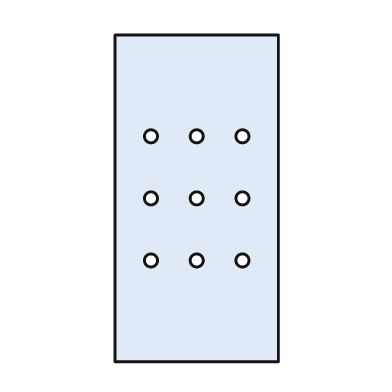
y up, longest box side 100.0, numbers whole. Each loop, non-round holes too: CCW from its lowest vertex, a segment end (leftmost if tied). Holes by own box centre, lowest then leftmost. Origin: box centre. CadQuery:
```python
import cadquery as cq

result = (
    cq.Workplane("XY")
    .moveTo(-25.0, -50.0)
    .lineTo(25.0, -50.0)
    .lineTo(25.0, 50.0)
    .lineTo(-25.0, 50.0)
    .close()
    .moveTo(-14.0, -19.0)
    .circle(2.0)
    .moveTo(0.0, -19.0)
    .circle(2.0)
    .moveTo(14.0, -19.0)
    .circle(2.0)
    .moveTo(-14.0, 0.0)
    .circle(2.0)
    .moveTo(0.0, 0.0)
    .circle(2.0)
    .moveTo(14.0, 0.0)
    .circle(2.0)
    .moveTo(-14.0, 19.0)
    .circle(2.0)
    .moveTo(0.0, 19.0)
    .circle(2.0)
    .moveTo(14.0, 19.0)
    .circle(2.0)
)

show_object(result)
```